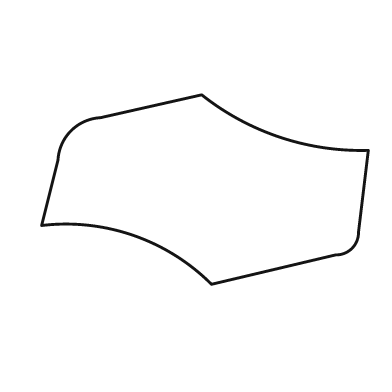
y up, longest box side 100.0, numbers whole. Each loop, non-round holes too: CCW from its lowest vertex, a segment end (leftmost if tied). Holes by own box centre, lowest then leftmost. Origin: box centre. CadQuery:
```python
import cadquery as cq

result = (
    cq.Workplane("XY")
    .moveTo(2.0, -29.0)
    .lineTo(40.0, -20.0)
    .threePointArc((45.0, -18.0), (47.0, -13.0))
    .lineTo(50.0, 12.0)
    .threePointArc((23.0, 16.0), (-1.0, 29.0))
    .lineTo(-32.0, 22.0)
    .threePointArc((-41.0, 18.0), (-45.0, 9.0))
    .lineTo(-50.0, -11.0)
    .threePointArc((-22.0, -14.0), (2.0, -29.0))
    .close()
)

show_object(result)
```